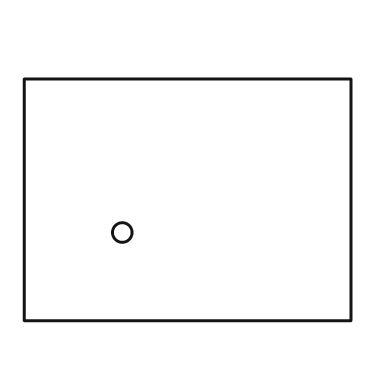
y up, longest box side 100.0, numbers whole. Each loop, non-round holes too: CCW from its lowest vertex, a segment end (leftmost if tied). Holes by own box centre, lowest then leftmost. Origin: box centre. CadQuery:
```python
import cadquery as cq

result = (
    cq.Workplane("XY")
    .moveTo(-50.0, -37.0)
    .lineTo(50.0, -37.0)
    .lineTo(50.0, 37.0)
    .lineTo(-50.0, 37.0)
    .close()
    .moveTo(-20.0, -10.0)
    .circle(3.0)
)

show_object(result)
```